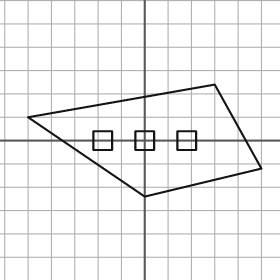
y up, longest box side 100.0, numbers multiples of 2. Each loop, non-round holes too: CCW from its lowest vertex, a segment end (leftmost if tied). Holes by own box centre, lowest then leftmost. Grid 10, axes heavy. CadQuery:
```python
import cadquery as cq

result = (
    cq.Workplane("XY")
    .moveTo(0.0, -24.0)
    .lineTo(50.0, -12.0)
    .lineTo(30.0, 24.0)
    .lineTo(-50.0, 10.0)
    .close()
    .moveTo(-22.0, -4.0)
    .lineTo(-14.0, -4.0)
    .lineTo(-14.0, 4.0)
    .lineTo(-22.0, 4.0)
    .close()
    .moveTo(-4.0, -4.0)
    .lineTo(4.0, -4.0)
    .lineTo(4.0, 4.0)
    .lineTo(-4.0, 4.0)
    .close()
    .moveTo(14.0, -4.0)
    .lineTo(22.0, -4.0)
    .lineTo(22.0, 4.0)
    .lineTo(14.0, 4.0)
    .close()
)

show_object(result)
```